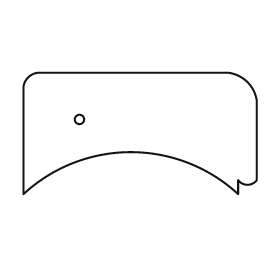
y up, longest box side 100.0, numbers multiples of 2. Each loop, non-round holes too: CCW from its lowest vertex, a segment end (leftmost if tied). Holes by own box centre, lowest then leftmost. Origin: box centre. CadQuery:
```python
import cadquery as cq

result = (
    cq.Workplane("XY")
    .moveTo(-50.0, -26.0)
    .threePointArc((-4.0, -8.0), (42.0, -26.0))
    .lineTo(42.0, -20.0)
    .threePointArc((46.0, -22.0), (50.0, -20.0))
    .lineTo(50.0, 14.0)
    .threePointArc((46.0, 22.0), (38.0, 26.0))
    .lineTo(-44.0, 26.0)
    .threePointArc((-48.0, 24.0), (-50.0, 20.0))
    .close()
    .moveTo(-26.0, 6.0)
    .circle(2.0)
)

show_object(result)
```